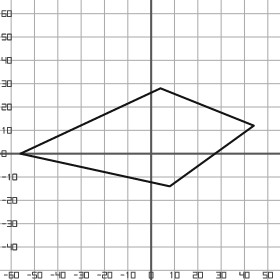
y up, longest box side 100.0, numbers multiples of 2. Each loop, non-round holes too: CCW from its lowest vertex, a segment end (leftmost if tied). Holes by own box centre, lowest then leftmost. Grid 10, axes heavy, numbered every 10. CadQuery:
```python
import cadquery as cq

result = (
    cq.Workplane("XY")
    .moveTo(8.0, -14.0)
    .lineTo(44.0, 12.0)
    .lineTo(4.0, 28.0)
    .lineTo(-56.0, 0.0)
    .close()
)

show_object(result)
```